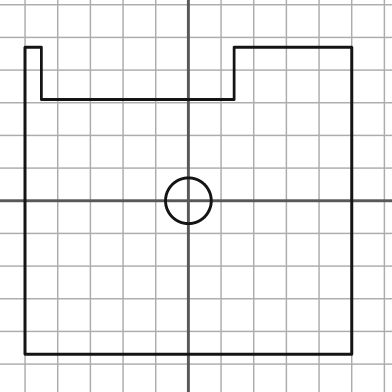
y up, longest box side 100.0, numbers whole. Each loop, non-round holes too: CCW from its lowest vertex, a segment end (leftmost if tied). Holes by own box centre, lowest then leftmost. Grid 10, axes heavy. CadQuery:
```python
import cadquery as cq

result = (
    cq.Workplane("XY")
    .moveTo(-50.0, -47.0)
    .lineTo(50.0, -47.0)
    .lineTo(50.0, 47.0)
    .lineTo(14.0, 47.0)
    .lineTo(14.0, 31.0)
    .lineTo(-45.0, 31.0)
    .lineTo(-45.0, 47.0)
    .lineTo(-50.0, 47.0)
    .close()
    .moveTo(0.0, 0.0)
    .circle(7.0)
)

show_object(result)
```